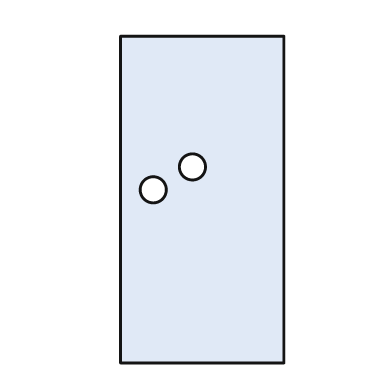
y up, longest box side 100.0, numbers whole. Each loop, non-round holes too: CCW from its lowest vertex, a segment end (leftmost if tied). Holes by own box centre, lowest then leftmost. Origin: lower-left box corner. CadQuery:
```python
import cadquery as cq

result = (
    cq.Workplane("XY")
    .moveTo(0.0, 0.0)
    .lineTo(50.0, 0.0)
    .lineTo(50.0, 100.0)
    .lineTo(0.0, 100.0)
    .close()
    .moveTo(10.0, 53.0)
    .circle(4.0)
    .moveTo(22.0, 60.0)
    .circle(4.0)
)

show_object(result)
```